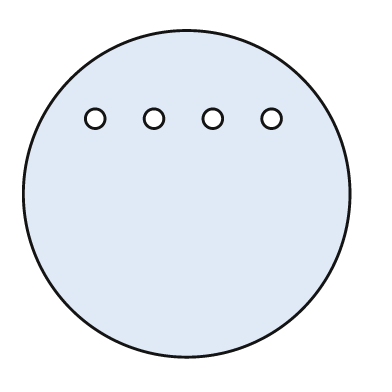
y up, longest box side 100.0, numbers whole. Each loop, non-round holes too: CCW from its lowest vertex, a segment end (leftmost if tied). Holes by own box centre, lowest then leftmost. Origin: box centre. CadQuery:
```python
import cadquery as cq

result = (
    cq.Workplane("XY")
    .moveTo(0.0, 0.0)
    .circle(50.0)
    .moveTo(-28.0, 23.0)
    .circle(3.0)
    .moveTo(-10.0, 23.0)
    .circle(3.0)
    .moveTo(8.0, 23.0)
    .circle(3.0)
    .moveTo(26.0, 23.0)
    .circle(3.0)
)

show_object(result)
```